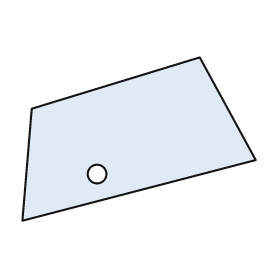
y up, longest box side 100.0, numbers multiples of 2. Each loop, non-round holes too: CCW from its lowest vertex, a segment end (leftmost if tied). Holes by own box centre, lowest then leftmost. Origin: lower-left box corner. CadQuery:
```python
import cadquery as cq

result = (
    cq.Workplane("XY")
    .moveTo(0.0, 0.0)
    .lineTo(100.0, 26.0)
    .lineTo(76.0, 70.0)
    .lineTo(4.0, 48.0)
    .close()
    .moveTo(32.0, 20.0)
    .circle(4.0)
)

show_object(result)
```